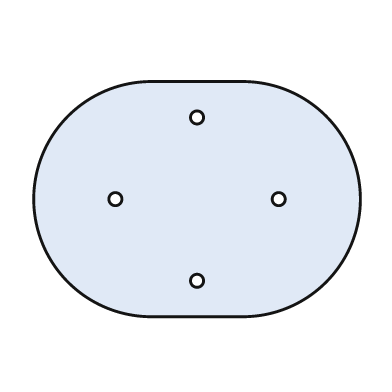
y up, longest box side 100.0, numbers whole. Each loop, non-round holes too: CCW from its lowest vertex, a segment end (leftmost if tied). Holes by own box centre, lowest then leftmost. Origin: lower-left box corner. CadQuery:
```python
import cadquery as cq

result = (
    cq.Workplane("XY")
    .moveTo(36.0, 0.0)
    .lineTo(64.0, 0.0)
    .threePointArc((100.0, 36.0), (64.0, 72.0))
    .lineTo(36.0, 72.0)
    .threePointArc((0.0, 36.0), (36.0, 0.0))
    .close()
    .moveTo(50.0, 11.0)
    .circle(2.0)
    .moveTo(25.0, 36.0)
    .circle(2.0)
    .moveTo(75.0, 36.0)
    .circle(2.0)
    .moveTo(50.0, 61.0)
    .circle(2.0)
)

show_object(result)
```